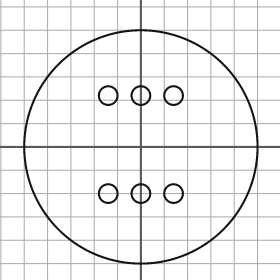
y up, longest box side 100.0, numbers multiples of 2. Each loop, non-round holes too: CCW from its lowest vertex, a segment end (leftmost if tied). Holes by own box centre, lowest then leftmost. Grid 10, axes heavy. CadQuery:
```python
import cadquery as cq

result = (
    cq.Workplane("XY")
    .moveTo(0.0, 0.0)
    .circle(50.0)
    .moveTo(-14.0, -20.0)
    .circle(4.0)
    .moveTo(0.0, -20.0)
    .circle(4.0)
    .moveTo(14.0, -20.0)
    .circle(4.0)
    .moveTo(-14.0, 22.0)
    .circle(4.0)
    .moveTo(0.0, 22.0)
    .circle(4.0)
    .moveTo(14.0, 22.0)
    .circle(4.0)
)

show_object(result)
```